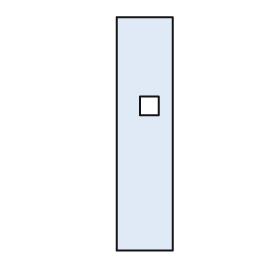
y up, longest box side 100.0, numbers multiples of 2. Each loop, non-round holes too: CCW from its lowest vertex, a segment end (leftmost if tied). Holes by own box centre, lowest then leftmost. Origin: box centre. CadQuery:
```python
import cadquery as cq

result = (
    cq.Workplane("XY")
    .moveTo(-12.0, -50.0)
    .lineTo(12.0, -50.0)
    .lineTo(12.0, 50.0)
    .lineTo(-12.0, 50.0)
    .close()
    .moveTo(-2.0, 8.0)
    .lineTo(6.0, 8.0)
    .lineTo(6.0, 16.0)
    .lineTo(-2.0, 16.0)
    .close()
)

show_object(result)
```